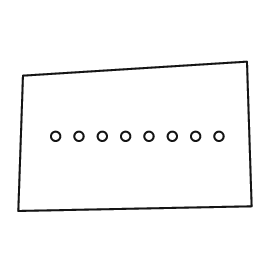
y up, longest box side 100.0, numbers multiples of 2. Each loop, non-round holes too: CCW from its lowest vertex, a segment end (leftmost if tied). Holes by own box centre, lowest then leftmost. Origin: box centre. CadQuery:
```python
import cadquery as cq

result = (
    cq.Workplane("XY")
    .moveTo(-50.0, -32.0)
    .lineTo(50.0, -30.0)
    .lineTo(48.0, 32.0)
    .lineTo(-48.0, 26.0)
    .close()
    .moveTo(-34.0, 0.0)
    .circle(2.0)
    .moveTo(-24.0, 0.0)
    .circle(2.0)
    .moveTo(-14.0, 0.0)
    .circle(2.0)
    .moveTo(-4.0, 0.0)
    .circle(2.0)
    .moveTo(6.0, 0.0)
    .circle(2.0)
    .moveTo(16.0, 0.0)
    .circle(2.0)
    .moveTo(26.0, 0.0)
    .circle(2.0)
    .moveTo(36.0, 0.0)
    .circle(2.0)
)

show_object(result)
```